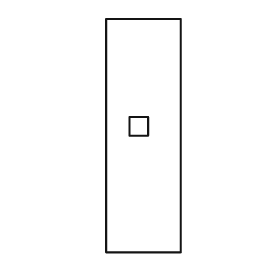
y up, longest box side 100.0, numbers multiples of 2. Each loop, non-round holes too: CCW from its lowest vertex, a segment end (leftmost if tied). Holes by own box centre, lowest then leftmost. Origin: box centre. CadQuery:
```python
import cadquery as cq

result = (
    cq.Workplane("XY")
    .moveTo(-16.0, -50.0)
    .lineTo(16.0, -50.0)
    .lineTo(16.0, 50.0)
    .lineTo(-16.0, 50.0)
    .close()
    .moveTo(-6.0, 0.0)
    .lineTo(2.0, 0.0)
    .lineTo(2.0, 8.0)
    .lineTo(-6.0, 8.0)
    .close()
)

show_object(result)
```